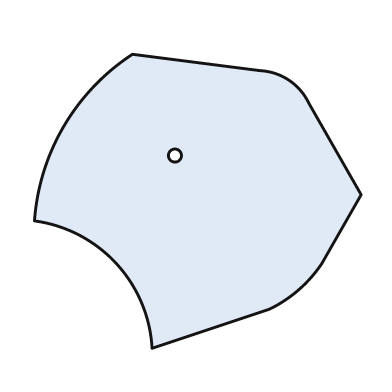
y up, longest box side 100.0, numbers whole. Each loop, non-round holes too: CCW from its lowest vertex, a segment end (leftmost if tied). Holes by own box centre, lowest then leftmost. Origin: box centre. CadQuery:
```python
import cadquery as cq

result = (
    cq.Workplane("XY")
    .moveTo(-14.0, -45.0)
    .lineTo(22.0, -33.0)
    .threePointArc((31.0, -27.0), (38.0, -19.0))
    .lineTo(50.0, 2.0)
    .lineTo(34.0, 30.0)
    .threePointArc((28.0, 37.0), (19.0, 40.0))
    .lineTo(-20.0, 45.0)
    .threePointArc((-41.0, 23.0), (-50.0, -6.0))
    .threePointArc((-25.0, -19.0), (-14.0, -45.0))
    .close()
    .moveTo(-7.0, 14.0)
    .circle(2.0)
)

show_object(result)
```